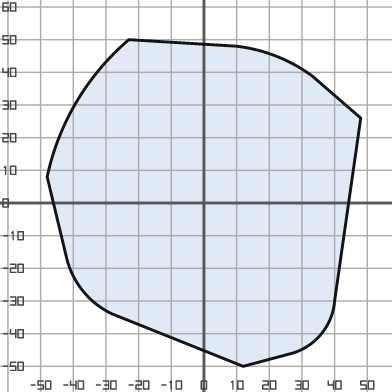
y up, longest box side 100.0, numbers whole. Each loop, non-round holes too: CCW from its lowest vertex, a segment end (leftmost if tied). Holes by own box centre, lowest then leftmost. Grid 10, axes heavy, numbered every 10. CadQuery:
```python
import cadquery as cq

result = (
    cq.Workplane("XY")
    .moveTo(12.0, -50.0)
    .lineTo(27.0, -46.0)
    .threePointArc((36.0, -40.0), (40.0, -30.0))
    .lineTo(48.0, 26.0)
    .lineTo(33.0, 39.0)
    .threePointArc((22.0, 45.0), (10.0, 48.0))
    .lineTo(-23.0, 50.0)
    .threePointArc((-39.0, 31.0), (-48.0, 8.0))
    .lineTo(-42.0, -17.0)
    .threePointArc((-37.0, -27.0), (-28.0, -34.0))
    .close()
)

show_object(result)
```